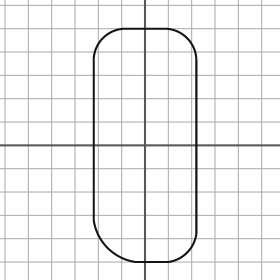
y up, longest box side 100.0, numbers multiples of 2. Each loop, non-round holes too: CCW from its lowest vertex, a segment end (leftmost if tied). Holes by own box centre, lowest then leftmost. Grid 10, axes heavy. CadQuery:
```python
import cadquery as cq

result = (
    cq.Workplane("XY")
    .moveTo(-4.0, -50.0)
    .lineTo(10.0, -50.0)
    .threePointArc((18.0, -46.0), (22.0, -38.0))
    .lineTo(22.0, 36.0)
    .threePointArc((18.0, 46.0), (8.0, 50.0))
    .lineTo(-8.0, 50.0)
    .threePointArc((-18.0, 46.0), (-22.0, 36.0))
    .lineTo(-22.0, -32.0)
    .threePointArc((-16.0, -44.0), (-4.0, -50.0))
    .close()
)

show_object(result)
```